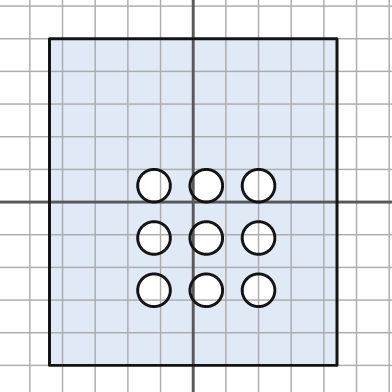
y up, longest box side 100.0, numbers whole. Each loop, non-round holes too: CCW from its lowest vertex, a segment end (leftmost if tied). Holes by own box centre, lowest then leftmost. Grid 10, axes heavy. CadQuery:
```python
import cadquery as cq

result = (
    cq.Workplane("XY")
    .moveTo(-44.0, -50.0)
    .lineTo(44.0, -50.0)
    .lineTo(44.0, 50.0)
    .lineTo(-44.0, 50.0)
    .close()
    .moveTo(-12.0, -27.0)
    .circle(5.0)
    .moveTo(4.0, -27.0)
    .circle(5.0)
    .moveTo(20.0, -27.0)
    .circle(5.0)
    .moveTo(-12.0, -11.0)
    .circle(5.0)
    .moveTo(4.0, -11.0)
    .circle(5.0)
    .moveTo(20.0, -11.0)
    .circle(5.0)
    .moveTo(-12.0, 5.0)
    .circle(5.0)
    .moveTo(4.0, 5.0)
    .circle(5.0)
    .moveTo(20.0, 5.0)
    .circle(5.0)
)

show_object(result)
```